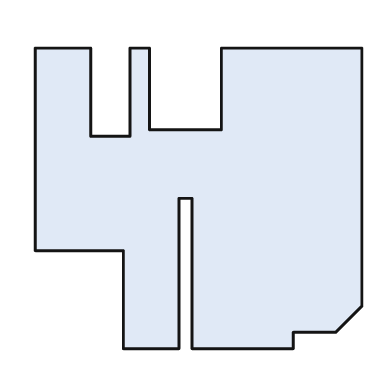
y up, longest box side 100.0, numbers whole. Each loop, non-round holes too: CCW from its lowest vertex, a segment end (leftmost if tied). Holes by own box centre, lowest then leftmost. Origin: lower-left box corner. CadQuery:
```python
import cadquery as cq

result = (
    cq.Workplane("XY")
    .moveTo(27.0, 0.0)
    .lineTo(44.0, 0.0)
    .lineTo(44.0, 46.0)
    .lineTo(48.0, 46.0)
    .lineTo(48.0, 0.0)
    .lineTo(79.0, 0.0)
    .lineTo(79.0, 5.0)
    .lineTo(92.0, 5.0)
    .lineTo(100.0, 13.0)
    .lineTo(100.0, 92.0)
    .lineTo(57.0, 92.0)
    .lineTo(57.0, 67.0)
    .lineTo(35.0, 67.0)
    .lineTo(35.0, 92.0)
    .lineTo(29.0, 92.0)
    .lineTo(29.0, 65.0)
    .lineTo(17.0, 65.0)
    .lineTo(17.0, 92.0)
    .lineTo(0.0, 92.0)
    .lineTo(0.0, 30.0)
    .lineTo(27.0, 30.0)
    .close()
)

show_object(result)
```